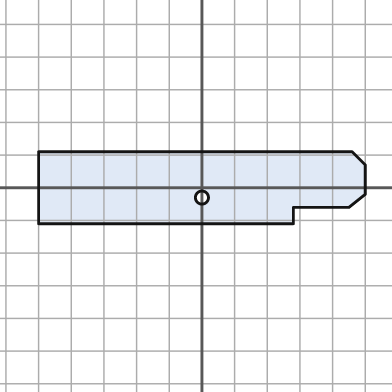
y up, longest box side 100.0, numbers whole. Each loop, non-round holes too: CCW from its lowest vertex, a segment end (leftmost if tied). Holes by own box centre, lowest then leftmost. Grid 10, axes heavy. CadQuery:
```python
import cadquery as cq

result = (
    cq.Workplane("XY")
    .moveTo(-50.0, -11.0)
    .lineTo(28.0, -11.0)
    .lineTo(28.0, -6.0)
    .lineTo(45.0, -6.0)
    .lineTo(50.0, -2.0)
    .lineTo(50.0, 7.0)
    .lineTo(46.0, 11.0)
    .lineTo(-50.0, 11.0)
    .close()
    .moveTo(0.0, -3.0)
    .circle(2.0)
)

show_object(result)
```